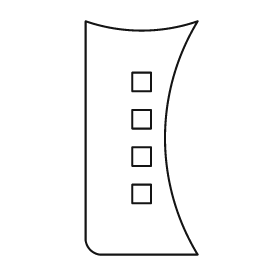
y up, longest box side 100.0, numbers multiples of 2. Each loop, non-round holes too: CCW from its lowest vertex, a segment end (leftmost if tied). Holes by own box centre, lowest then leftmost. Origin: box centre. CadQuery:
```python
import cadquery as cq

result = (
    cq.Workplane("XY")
    .moveTo(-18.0, -50.0)
    .lineTo(24.0, -50.0)
    .threePointArc((10.0, 0.0), (24.0, 50.0))
    .threePointArc((0.0, 46.0), (-24.0, 50.0))
    .lineTo(-24.0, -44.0)
    .threePointArc((-22.0, -48.0), (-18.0, -50.0))
    .close()
    .moveTo(-4.0, -28.0)
    .lineTo(4.0, -28.0)
    .lineTo(4.0, -20.0)
    .lineTo(-4.0, -20.0)
    .close()
    .moveTo(-4.0, -12.0)
    .lineTo(4.0, -12.0)
    .lineTo(4.0, -4.0)
    .lineTo(-4.0, -4.0)
    .close()
    .moveTo(-4.0, 4.0)
    .lineTo(4.0, 4.0)
    .lineTo(4.0, 12.0)
    .lineTo(-4.0, 12.0)
    .close()
    .moveTo(-4.0, 20.0)
    .lineTo(4.0, 20.0)
    .lineTo(4.0, 28.0)
    .lineTo(-4.0, 28.0)
    .close()
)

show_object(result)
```